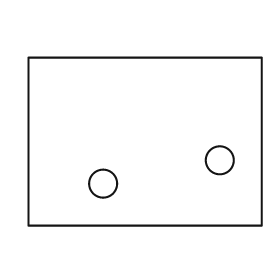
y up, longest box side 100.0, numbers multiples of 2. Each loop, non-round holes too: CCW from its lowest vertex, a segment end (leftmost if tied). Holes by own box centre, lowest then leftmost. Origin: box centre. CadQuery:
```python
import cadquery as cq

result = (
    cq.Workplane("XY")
    .moveTo(-50.0, -36.0)
    .lineTo(50.0, -36.0)
    .lineTo(50.0, 36.0)
    .lineTo(-50.0, 36.0)
    .close()
    .moveTo(-18.0, -18.0)
    .circle(6.0)
    .moveTo(32.0, -8.0)
    .circle(6.0)
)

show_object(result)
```